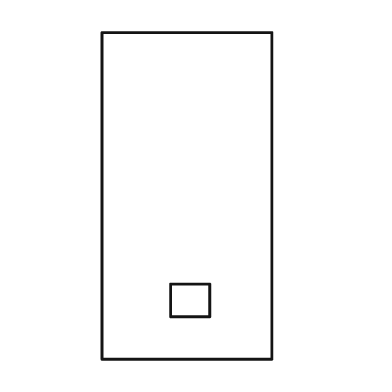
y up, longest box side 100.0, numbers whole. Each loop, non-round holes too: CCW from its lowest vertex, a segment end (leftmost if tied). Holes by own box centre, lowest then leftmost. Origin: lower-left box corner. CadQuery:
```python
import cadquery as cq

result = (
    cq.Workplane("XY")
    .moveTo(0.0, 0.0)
    .lineTo(52.0, 0.0)
    .lineTo(52.0, 100.0)
    .lineTo(0.0, 100.0)
    .close()
    .moveTo(21.0, 13.0)
    .lineTo(33.0, 13.0)
    .lineTo(33.0, 23.0)
    .lineTo(21.0, 23.0)
    .close()
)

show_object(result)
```